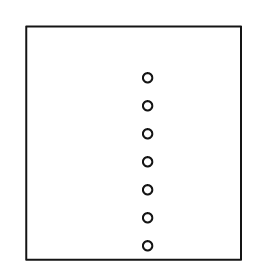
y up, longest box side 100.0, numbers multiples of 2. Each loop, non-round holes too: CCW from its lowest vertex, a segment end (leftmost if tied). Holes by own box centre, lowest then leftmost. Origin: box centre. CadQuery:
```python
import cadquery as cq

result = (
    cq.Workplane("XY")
    .moveTo(-46.0, -50.0)
    .lineTo(46.0, -50.0)
    .lineTo(46.0, 50.0)
    .lineTo(-46.0, 50.0)
    .close()
    .moveTo(6.0, -44.0)
    .circle(2.0)
    .moveTo(6.0, -32.0)
    .circle(2.0)
    .moveTo(6.0, -20.0)
    .circle(2.0)
    .moveTo(6.0, -8.0)
    .circle(2.0)
    .moveTo(6.0, 4.0)
    .circle(2.0)
    .moveTo(6.0, 16.0)
    .circle(2.0)
    .moveTo(6.0, 28.0)
    .circle(2.0)
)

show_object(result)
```